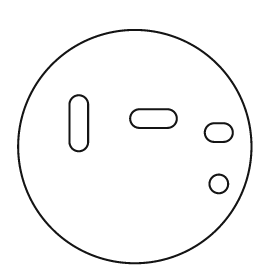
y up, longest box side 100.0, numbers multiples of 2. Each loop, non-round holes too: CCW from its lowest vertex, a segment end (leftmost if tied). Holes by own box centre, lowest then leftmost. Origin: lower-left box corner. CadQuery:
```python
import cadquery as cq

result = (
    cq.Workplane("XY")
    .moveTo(50.0, 50.0)
    .circle(50.0)
    .moveTo(86.0, 34.0)
    .circle(4.0)
    .moveTo(84.0, 52.0)
    .lineTo(88.0, 52.0)
    .threePointArc((92.0, 56.0), (88.0, 60.0))
    .lineTo(84.0, 60.0)
    .threePointArc((80.0, 56.0), (84.0, 52.0))
    .close()
    .moveTo(22.0, 52.0)
    .threePointArc((26.0, 48.0), (30.0, 52.0))
    .lineTo(30.0, 68.0)
    .threePointArc((26.0, 72.0), (22.0, 68.0))
    .close()
    .moveTo(52.0, 58.0)
    .lineTo(64.0, 58.0)
    .threePointArc((68.0, 62.0), (64.0, 66.0))
    .lineTo(52.0, 66.0)
    .threePointArc((48.0, 62.0), (52.0, 58.0))
    .close()
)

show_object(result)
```